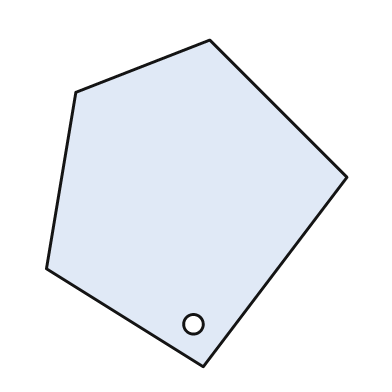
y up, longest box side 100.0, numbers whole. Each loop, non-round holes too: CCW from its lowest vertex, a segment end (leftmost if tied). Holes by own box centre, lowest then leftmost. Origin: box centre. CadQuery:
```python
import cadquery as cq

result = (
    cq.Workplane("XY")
    .moveTo(2.0, -50.0)
    .lineTo(46.0, 8.0)
    .lineTo(4.0, 50.0)
    .lineTo(-37.0, 34.0)
    .lineTo(-46.0, -20.0)
    .close()
    .moveTo(-1.0, -37.0)
    .circle(3.0)
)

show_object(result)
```